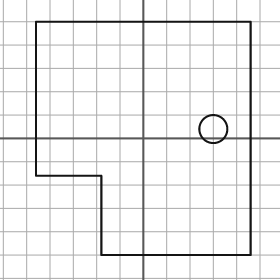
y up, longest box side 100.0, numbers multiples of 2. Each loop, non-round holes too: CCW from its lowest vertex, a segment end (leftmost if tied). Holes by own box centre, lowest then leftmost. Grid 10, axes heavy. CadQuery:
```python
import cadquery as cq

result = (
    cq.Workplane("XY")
    .moveTo(-18.0, -50.0)
    .lineTo(46.0, -50.0)
    .lineTo(46.0, 50.0)
    .lineTo(-46.0, 50.0)
    .lineTo(-46.0, -16.0)
    .lineTo(-18.0, -16.0)
    .close()
    .moveTo(30.0, 4.0)
    .circle(6.0)
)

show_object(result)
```